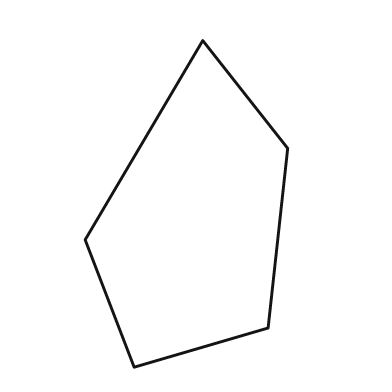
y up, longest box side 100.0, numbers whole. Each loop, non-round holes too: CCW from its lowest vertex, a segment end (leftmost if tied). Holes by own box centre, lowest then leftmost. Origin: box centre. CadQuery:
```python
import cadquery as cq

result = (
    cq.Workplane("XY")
    .moveTo(-16.0, -50.0)
    .lineTo(25.0, -38.0)
    .lineTo(31.0, 17.0)
    .lineTo(5.0, 50.0)
    .lineTo(-31.0, -11.0)
    .close()
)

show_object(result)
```